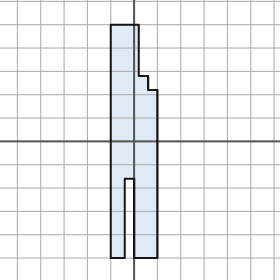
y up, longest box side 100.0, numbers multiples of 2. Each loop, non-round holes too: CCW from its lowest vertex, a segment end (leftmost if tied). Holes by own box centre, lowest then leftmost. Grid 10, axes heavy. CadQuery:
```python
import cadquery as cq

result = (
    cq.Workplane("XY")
    .moveTo(-10.0, -50.0)
    .lineTo(-4.0, -50.0)
    .lineTo(-4.0, -16.0)
    .lineTo(0.0, -16.0)
    .lineTo(0.0, -50.0)
    .lineTo(10.0, -50.0)
    .lineTo(10.0, 22.0)
    .lineTo(6.0, 22.0)
    .lineTo(6.0, 28.0)
    .lineTo(2.0, 28.0)
    .lineTo(2.0, 50.0)
    .lineTo(-10.0, 50.0)
    .close()
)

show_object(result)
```